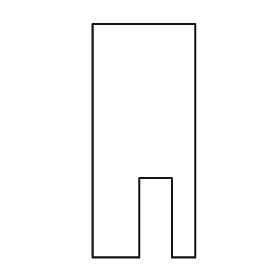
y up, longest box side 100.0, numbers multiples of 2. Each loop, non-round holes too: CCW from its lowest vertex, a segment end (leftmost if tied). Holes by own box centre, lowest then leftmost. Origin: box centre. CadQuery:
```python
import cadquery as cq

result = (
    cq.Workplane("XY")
    .moveTo(-22.0, -50.0)
    .lineTo(-2.0, -50.0)
    .lineTo(-2.0, -16.0)
    .lineTo(12.0, -16.0)
    .lineTo(12.0, -50.0)
    .lineTo(22.0, -50.0)
    .lineTo(22.0, 50.0)
    .lineTo(-22.0, 50.0)
    .close()
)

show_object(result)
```